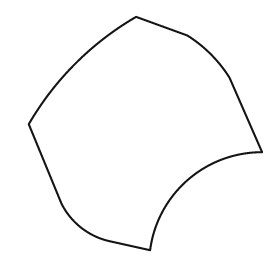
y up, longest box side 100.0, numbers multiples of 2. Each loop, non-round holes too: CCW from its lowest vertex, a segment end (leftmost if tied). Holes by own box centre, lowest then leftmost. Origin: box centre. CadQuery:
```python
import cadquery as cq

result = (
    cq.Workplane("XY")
    .moveTo(2.0, -50.0)
    .threePointArc((18.0, -20.0), (50.0, -8.0))
    .lineTo(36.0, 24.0)
    .threePointArc((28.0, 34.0), (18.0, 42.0))
    .lineTo(-4.0, 50.0)
    .threePointArc((-30.0, 30.0), (-50.0, 4.0))
    .lineTo(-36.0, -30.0)
    .threePointArc((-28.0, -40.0), (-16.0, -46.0))
    .close()
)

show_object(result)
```